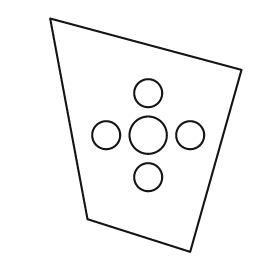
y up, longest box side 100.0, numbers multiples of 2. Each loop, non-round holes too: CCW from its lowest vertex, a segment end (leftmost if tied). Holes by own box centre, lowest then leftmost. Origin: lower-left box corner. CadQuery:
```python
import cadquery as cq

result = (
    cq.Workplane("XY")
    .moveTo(60.0, 0.0)
    .lineTo(82.0, 78.0)
    .lineTo(0.0, 100.0)
    .lineTo(16.0, 14.0)
    .close()
    .moveTo(42.0, 32.0)
    .circle(6.0)
    .moveTo(24.0, 50.0)
    .circle(6.0)
    .moveTo(42.0, 50.0)
    .circle(8.0)
    .moveTo(60.0, 50.0)
    .circle(6.0)
    .moveTo(42.0, 68.0)
    .circle(6.0)
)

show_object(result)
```